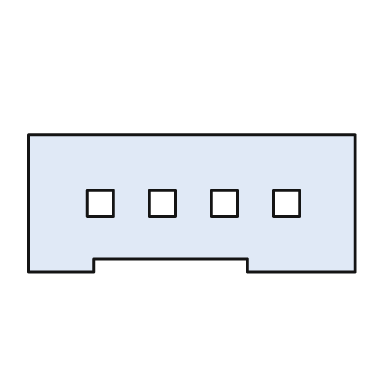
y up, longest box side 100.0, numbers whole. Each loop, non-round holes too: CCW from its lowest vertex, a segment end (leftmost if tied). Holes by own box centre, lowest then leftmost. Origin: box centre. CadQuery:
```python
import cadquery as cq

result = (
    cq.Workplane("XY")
    .moveTo(-50.0, -21.0)
    .lineTo(-30.0, -21.0)
    .lineTo(-30.0, -17.0)
    .lineTo(17.0, -17.0)
    .lineTo(17.0, -21.0)
    .lineTo(50.0, -21.0)
    .lineTo(50.0, 21.0)
    .lineTo(-50.0, 21.0)
    .close()
    .moveTo(-32.0, -4.0)
    .lineTo(-24.0, -4.0)
    .lineTo(-24.0, 4.0)
    .lineTo(-32.0, 4.0)
    .close()
    .moveTo(-13.0, -4.0)
    .lineTo(-5.0, -4.0)
    .lineTo(-5.0, 4.0)
    .lineTo(-13.0, 4.0)
    .close()
    .moveTo(6.0, -4.0)
    .lineTo(14.0, -4.0)
    .lineTo(14.0, 4.0)
    .lineTo(6.0, 4.0)
    .close()
    .moveTo(25.0, -4.0)
    .lineTo(33.0, -4.0)
    .lineTo(33.0, 4.0)
    .lineTo(25.0, 4.0)
    .close()
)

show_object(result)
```